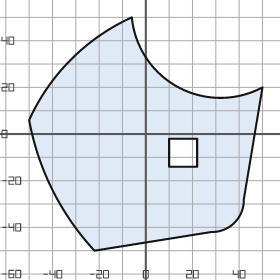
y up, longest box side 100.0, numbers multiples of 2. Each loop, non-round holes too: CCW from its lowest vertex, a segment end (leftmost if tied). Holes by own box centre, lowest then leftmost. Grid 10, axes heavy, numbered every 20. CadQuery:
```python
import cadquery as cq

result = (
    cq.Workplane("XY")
    .moveTo(-22.0, -50.0)
    .lineTo(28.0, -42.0)
    .threePointArc((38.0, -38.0), (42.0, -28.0))
    .lineTo(50.0, 20.0)
    .threePointArc((14.0, 20.0), (-6.0, 50.0))
    .threePointArc((-32.0, 32.0), (-50.0, 6.0))
    .threePointArc((-40.0, -24.0), (-22.0, -50.0))
    .close()
    .moveTo(10.0, -14.0)
    .lineTo(22.0, -14.0)
    .lineTo(22.0, -2.0)
    .lineTo(10.0, -2.0)
    .close()
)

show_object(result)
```